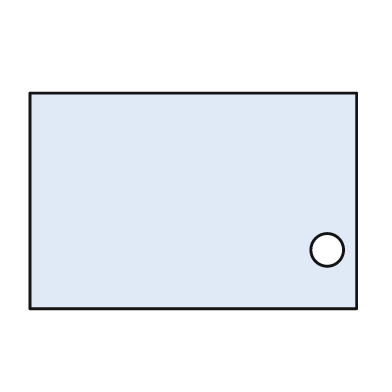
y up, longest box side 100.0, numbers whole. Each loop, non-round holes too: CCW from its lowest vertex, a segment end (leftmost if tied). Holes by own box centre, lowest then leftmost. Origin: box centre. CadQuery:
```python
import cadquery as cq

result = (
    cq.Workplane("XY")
    .moveTo(-50.0, -33.0)
    .lineTo(50.0, -33.0)
    .lineTo(50.0, 33.0)
    .lineTo(-50.0, 33.0)
    .close()
    .moveTo(41.0, -15.0)
    .circle(5.0)
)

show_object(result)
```